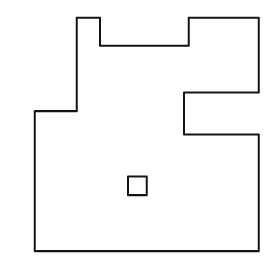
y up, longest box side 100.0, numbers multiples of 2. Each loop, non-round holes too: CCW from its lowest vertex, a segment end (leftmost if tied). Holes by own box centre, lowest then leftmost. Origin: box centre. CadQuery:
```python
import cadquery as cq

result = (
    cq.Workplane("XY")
    .moveTo(-48.0, -50.0)
    .lineTo(48.0, -50.0)
    .lineTo(48.0, 0.0)
    .lineTo(16.0, 0.0)
    .lineTo(16.0, 18.0)
    .lineTo(48.0, 18.0)
    .lineTo(48.0, 50.0)
    .lineTo(18.0, 50.0)
    .lineTo(18.0, 38.0)
    .lineTo(-20.0, 38.0)
    .lineTo(-20.0, 50.0)
    .lineTo(-30.0, 50.0)
    .lineTo(-30.0, 10.0)
    .lineTo(-48.0, 10.0)
    .close()
    .moveTo(-8.0, -26.0)
    .lineTo(0.0, -26.0)
    .lineTo(0.0, -18.0)
    .lineTo(-8.0, -18.0)
    .close()
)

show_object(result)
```